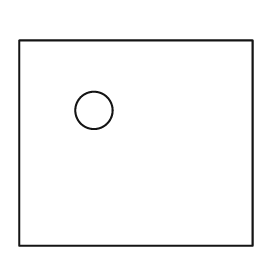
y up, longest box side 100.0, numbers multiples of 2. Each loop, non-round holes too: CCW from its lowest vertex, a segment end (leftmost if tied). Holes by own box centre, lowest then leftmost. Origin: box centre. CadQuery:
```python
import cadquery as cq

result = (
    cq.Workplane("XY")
    .moveTo(-50.0, -44.0)
    .lineTo(50.0, -44.0)
    .lineTo(50.0, 44.0)
    .lineTo(-50.0, 44.0)
    .close()
    .moveTo(-18.0, 14.0)
    .circle(8.0)
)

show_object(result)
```